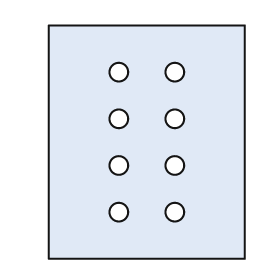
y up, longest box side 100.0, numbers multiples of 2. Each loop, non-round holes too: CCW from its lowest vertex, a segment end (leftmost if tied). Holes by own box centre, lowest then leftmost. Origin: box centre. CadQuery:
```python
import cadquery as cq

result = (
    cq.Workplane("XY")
    .moveTo(-42.0, -50.0)
    .lineTo(42.0, -50.0)
    .lineTo(42.0, 50.0)
    .lineTo(-42.0, 50.0)
    .close()
    .moveTo(-12.0, -30.0)
    .circle(4.0)
    .moveTo(12.0, -30.0)
    .circle(4.0)
    .moveTo(-12.0, -10.0)
    .circle(4.0)
    .moveTo(12.0, -10.0)
    .circle(4.0)
    .moveTo(-12.0, 10.0)
    .circle(4.0)
    .moveTo(12.0, 10.0)
    .circle(4.0)
    .moveTo(-12.0, 30.0)
    .circle(4.0)
    .moveTo(12.0, 30.0)
    .circle(4.0)
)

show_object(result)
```